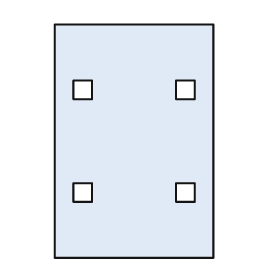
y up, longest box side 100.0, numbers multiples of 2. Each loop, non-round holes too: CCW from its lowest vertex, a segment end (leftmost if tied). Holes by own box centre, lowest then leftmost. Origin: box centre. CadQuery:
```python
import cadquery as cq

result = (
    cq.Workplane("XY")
    .moveTo(-34.0, -50.0)
    .lineTo(34.0, -50.0)
    .lineTo(34.0, 50.0)
    .lineTo(-34.0, 50.0)
    .close()
    .moveTo(-26.0, -26.0)
    .lineTo(-18.0, -26.0)
    .lineTo(-18.0, -18.0)
    .lineTo(-26.0, -18.0)
    .close()
    .moveTo(18.0, -26.0)
    .lineTo(26.0, -26.0)
    .lineTo(26.0, -18.0)
    .lineTo(18.0, -18.0)
    .close()
    .moveTo(-26.0, 18.0)
    .lineTo(-18.0, 18.0)
    .lineTo(-18.0, 26.0)
    .lineTo(-26.0, 26.0)
    .close()
    .moveTo(18.0, 18.0)
    .lineTo(26.0, 18.0)
    .lineTo(26.0, 26.0)
    .lineTo(18.0, 26.0)
    .close()
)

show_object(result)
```